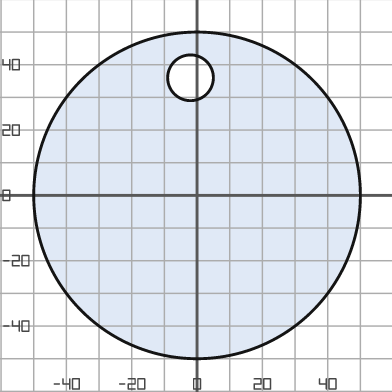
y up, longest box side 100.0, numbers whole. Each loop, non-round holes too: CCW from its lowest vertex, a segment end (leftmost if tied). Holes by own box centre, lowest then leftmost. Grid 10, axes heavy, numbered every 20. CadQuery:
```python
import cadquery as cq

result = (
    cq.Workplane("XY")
    .moveTo(0.0, 0.0)
    .circle(50.0)
    .moveTo(-2.0, 36.0)
    .circle(7.0)
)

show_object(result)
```